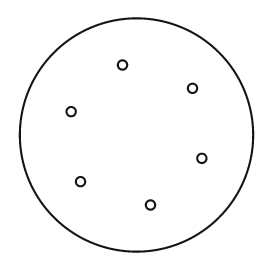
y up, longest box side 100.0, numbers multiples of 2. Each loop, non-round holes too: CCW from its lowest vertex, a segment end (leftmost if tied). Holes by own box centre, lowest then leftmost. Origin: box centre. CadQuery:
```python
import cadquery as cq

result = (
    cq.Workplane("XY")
    .moveTo(0.0, 0.0)
    .circle(50.0)
    .moveTo(6.0, -30.0)
    .circle(2.0)
    .moveTo(-24.0, -20.0)
    .circle(2.0)
    .moveTo(28.0, -10.0)
    .circle(2.0)
    .moveTo(-28.0, 10.0)
    .circle(2.0)
    .moveTo(24.0, 20.0)
    .circle(2.0)
    .moveTo(-6.0, 30.0)
    .circle(2.0)
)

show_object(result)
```